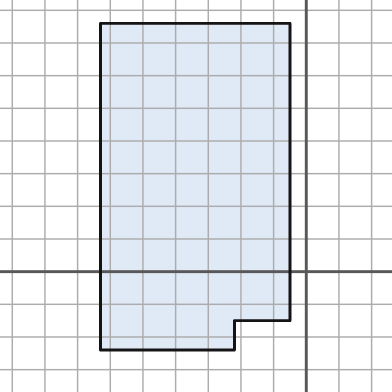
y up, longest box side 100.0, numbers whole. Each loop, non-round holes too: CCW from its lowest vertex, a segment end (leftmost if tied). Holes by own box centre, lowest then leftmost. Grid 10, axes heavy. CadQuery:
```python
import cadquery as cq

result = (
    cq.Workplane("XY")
    .moveTo(-63.0, -24.0)
    .lineTo(-22.0, -24.0)
    .lineTo(-22.0, -15.0)
    .lineTo(-5.0, -15.0)
    .lineTo(-5.0, 76.0)
    .lineTo(-63.0, 76.0)
    .close()
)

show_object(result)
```